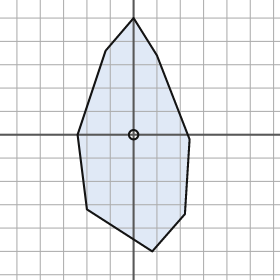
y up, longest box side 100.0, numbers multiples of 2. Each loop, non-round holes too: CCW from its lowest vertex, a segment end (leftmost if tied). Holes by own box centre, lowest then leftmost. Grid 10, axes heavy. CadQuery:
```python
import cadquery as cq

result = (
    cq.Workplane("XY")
    .moveTo(8.0, -50.0)
    .lineTo(22.0, -34.0)
    .lineTo(24.0, -2.0)
    .lineTo(10.0, 34.0)
    .lineTo(0.0, 50.0)
    .lineTo(-12.0, 36.0)
    .lineTo(-24.0, 0.0)
    .lineTo(-20.0, -32.0)
    .close()
    .moveTo(0.0, 0.0)
    .circle(2.0)
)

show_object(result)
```